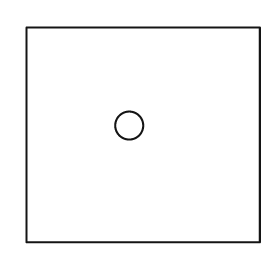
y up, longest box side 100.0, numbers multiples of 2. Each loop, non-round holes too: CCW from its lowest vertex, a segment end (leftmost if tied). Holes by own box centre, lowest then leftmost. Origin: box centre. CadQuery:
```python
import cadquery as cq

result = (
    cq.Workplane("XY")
    .moveTo(-50.0, -46.0)
    .lineTo(50.0, -46.0)
    .lineTo(50.0, 46.0)
    .lineTo(-50.0, 46.0)
    .close()
    .moveTo(-6.0, 4.0)
    .circle(6.0)
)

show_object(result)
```